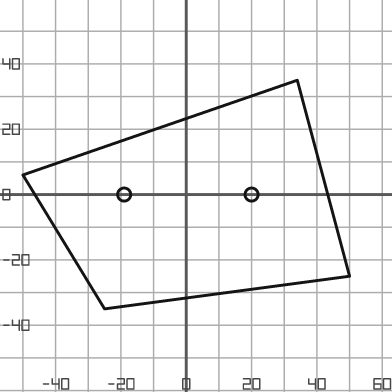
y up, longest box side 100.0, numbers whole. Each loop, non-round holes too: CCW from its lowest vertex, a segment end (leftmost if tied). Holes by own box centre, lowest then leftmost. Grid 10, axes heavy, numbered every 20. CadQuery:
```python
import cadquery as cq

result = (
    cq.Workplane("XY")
    .moveTo(-25.0, -35.0)
    .lineTo(50.0, -25.0)
    .lineTo(34.0, 35.0)
    .lineTo(-50.0, 6.0)
    .close()
    .moveTo(-19.0, 0.0)
    .circle(2.0)
    .moveTo(20.0, 0.0)
    .circle(2.0)
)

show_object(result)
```